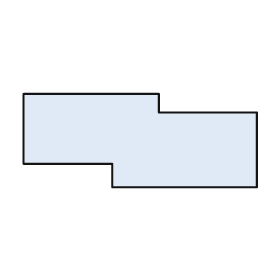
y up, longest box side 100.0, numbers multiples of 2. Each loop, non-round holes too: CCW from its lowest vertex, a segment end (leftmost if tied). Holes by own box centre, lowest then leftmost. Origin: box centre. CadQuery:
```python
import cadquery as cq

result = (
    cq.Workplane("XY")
    .moveTo(-12.0, -20.0)
    .lineTo(50.0, -20.0)
    .lineTo(50.0, 12.0)
    .lineTo(8.0, 12.0)
    .lineTo(8.0, 20.0)
    .lineTo(-50.0, 20.0)
    .lineTo(-50.0, -10.0)
    .lineTo(-12.0, -10.0)
    .close()
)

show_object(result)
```